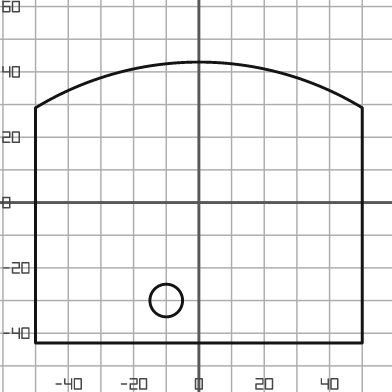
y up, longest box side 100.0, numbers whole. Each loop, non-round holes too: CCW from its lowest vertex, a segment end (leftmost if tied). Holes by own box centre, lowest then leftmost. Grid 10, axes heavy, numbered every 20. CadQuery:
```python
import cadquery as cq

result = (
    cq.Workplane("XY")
    .moveTo(-50.0, -43.0)
    .lineTo(50.0, -43.0)
    .lineTo(50.0, 29.0)
    .threePointArc((0.0, 43.0), (-50.0, 29.0))
    .close()
    .moveTo(-10.0, -30.0)
    .circle(5.0)
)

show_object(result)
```